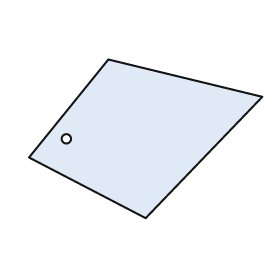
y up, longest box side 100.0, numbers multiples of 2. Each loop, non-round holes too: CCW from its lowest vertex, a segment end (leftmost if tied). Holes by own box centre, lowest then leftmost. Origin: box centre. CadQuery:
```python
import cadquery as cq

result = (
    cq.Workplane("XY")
    .moveTo(0.0, -34.0)
    .lineTo(50.0, 18.0)
    .lineTo(-16.0, 34.0)
    .lineTo(-50.0, -8.0)
    .close()
    .moveTo(-34.0, 0.0)
    .circle(2.0)
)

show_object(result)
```